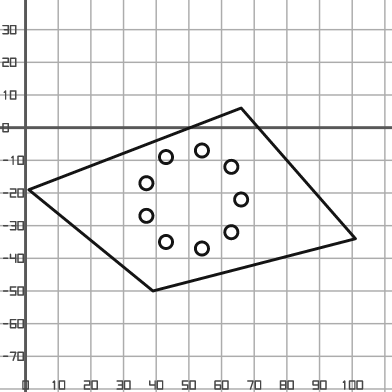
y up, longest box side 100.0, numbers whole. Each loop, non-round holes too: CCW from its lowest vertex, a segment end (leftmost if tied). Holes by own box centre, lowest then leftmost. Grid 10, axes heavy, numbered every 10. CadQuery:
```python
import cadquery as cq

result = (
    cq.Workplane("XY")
    .moveTo(39.0, -50.0)
    .lineTo(101.0, -34.0)
    .lineTo(66.0, 6.0)
    .lineTo(1.0, -19.0)
    .close()
    .moveTo(54.0, -37.0)
    .circle(2.0)
    .moveTo(43.0, -35.0)
    .circle(2.0)
    .moveTo(63.0, -32.0)
    .circle(2.0)
    .moveTo(37.0, -27.0)
    .circle(2.0)
    .moveTo(66.0, -22.0)
    .circle(2.0)
    .moveTo(37.0, -17.0)
    .circle(2.0)
    .moveTo(63.0, -12.0)
    .circle(2.0)
    .moveTo(43.0, -9.0)
    .circle(2.0)
    .moveTo(54.0, -7.0)
    .circle(2.0)
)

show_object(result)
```